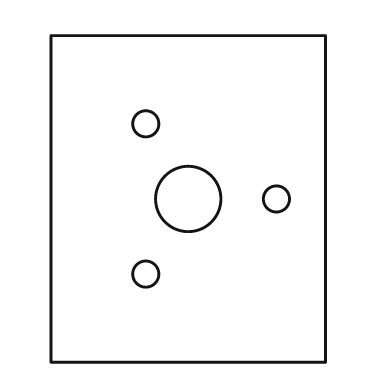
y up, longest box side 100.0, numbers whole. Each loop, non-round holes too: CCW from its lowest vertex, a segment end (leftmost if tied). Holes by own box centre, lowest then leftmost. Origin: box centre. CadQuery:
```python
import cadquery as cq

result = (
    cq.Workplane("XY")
    .moveTo(-42.0, -50.0)
    .lineTo(42.0, -50.0)
    .lineTo(42.0, 50.0)
    .lineTo(-42.0, 50.0)
    .close()
    .moveTo(-13.0, -23.0)
    .circle(4.0)
    .moveTo(0.0, 0.0)
    .circle(10.0)
    .moveTo(27.0, 0.0)
    .circle(4.0)
    .moveTo(-13.0, 23.0)
    .circle(4.0)
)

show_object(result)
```